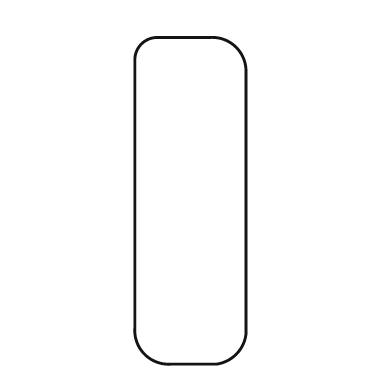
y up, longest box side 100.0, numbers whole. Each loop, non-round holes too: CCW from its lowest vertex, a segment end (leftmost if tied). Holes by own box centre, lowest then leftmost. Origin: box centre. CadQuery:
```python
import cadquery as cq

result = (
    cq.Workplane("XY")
    .moveTo(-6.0, -50.0)
    .lineTo(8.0, -50.0)
    .threePointArc((14.0, -47.0), (17.0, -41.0))
    .lineTo(17.0, 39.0)
    .threePointArc((14.0, 47.0), (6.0, 50.0))
    .lineTo(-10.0, 50.0)
    .threePointArc((-15.0, 48.0), (-17.0, 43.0))
    .lineTo(-17.0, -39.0)
    .threePointArc((-14.0, -47.0), (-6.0, -50.0))
    .close()
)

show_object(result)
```